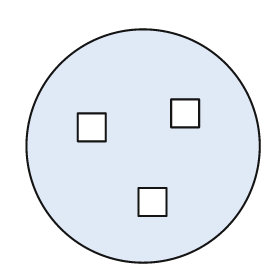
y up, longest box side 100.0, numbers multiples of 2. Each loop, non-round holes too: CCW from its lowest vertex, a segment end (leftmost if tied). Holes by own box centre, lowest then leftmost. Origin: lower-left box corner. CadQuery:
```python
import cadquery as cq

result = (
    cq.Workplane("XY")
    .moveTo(50.0, 50.0)
    .circle(50.0)
    .moveTo(48.0, 20.0)
    .lineTo(60.0, 20.0)
    .lineTo(60.0, 32.0)
    .lineTo(48.0, 32.0)
    .close()
    .moveTo(22.0, 52.0)
    .lineTo(34.0, 52.0)
    .lineTo(34.0, 64.0)
    .lineTo(22.0, 64.0)
    .close()
    .moveTo(62.0, 58.0)
    .lineTo(74.0, 58.0)
    .lineTo(74.0, 70.0)
    .lineTo(62.0, 70.0)
    .close()
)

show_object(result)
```